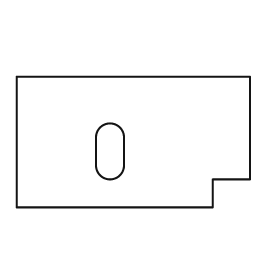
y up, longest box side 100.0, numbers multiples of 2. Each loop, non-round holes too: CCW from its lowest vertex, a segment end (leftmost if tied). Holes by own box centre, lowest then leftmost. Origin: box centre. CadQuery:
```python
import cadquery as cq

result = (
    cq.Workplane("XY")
    .moveTo(-50.0, -28.0)
    .lineTo(34.0, -28.0)
    .lineTo(34.0, -16.0)
    .lineTo(50.0, -16.0)
    .lineTo(50.0, 28.0)
    .lineTo(-50.0, 28.0)
    .close()
    .moveTo(-16.0, -10.0)
    .threePointArc((-10.0, -16.0), (-4.0, -10.0))
    .lineTo(-4.0, 2.0)
    .threePointArc((-10.0, 8.0), (-16.0, 2.0))
    .close()
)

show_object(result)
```